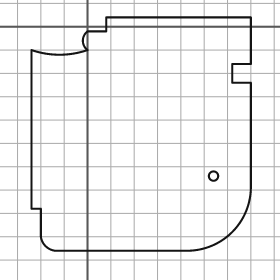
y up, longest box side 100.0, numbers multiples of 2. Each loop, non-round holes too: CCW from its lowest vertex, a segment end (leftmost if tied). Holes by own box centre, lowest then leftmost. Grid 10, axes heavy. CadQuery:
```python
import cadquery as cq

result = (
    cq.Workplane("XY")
    .moveTo(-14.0, -96.0)
    .lineTo(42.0, -96.0)
    .threePointArc((62.0, -88.0), (70.0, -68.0))
    .lineTo(70.0, -24.0)
    .lineTo(62.0, -24.0)
    .lineTo(62.0, -16.0)
    .lineTo(70.0, -16.0)
    .lineTo(70.0, 4.0)
    .lineTo(8.0, 4.0)
    .lineTo(8.0, -2.0)
    .lineTo(0.0, -2.0)
    .threePointArc((-2.0, -6.0), (0.0, -10.0))
    .threePointArc((-12.0, -12.0), (-24.0, -10.0))
    .lineTo(-24.0, -78.0)
    .lineTo(-20.0, -78.0)
    .lineTo(-20.0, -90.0)
    .threePointArc((-18.0, -94.0), (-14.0, -96.0))
    .close()
    .moveTo(54.0, -64.0)
    .circle(2.0)
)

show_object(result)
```